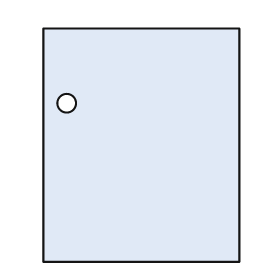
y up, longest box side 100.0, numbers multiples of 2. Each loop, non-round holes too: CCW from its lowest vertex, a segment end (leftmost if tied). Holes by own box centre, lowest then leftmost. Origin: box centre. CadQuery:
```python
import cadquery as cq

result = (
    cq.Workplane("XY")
    .moveTo(-42.0, -50.0)
    .lineTo(42.0, -50.0)
    .lineTo(42.0, 50.0)
    .lineTo(-42.0, 50.0)
    .close()
    .moveTo(-32.0, 18.0)
    .circle(4.0)
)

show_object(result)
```